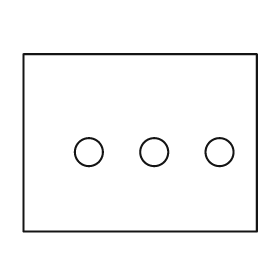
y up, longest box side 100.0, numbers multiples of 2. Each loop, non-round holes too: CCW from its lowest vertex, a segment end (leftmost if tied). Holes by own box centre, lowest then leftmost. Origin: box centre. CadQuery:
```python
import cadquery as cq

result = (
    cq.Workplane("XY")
    .moveTo(-50.0, -38.0)
    .lineTo(50.0, -38.0)
    .lineTo(50.0, 38.0)
    .lineTo(-50.0, 38.0)
    .close()
    .moveTo(-22.0, -4.0)
    .circle(6.0)
    .moveTo(6.0, -4.0)
    .circle(6.0)
    .moveTo(34.0, -4.0)
    .circle(6.0)
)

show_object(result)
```